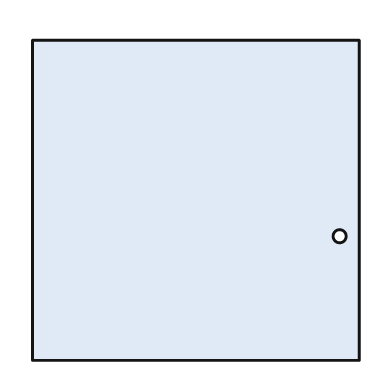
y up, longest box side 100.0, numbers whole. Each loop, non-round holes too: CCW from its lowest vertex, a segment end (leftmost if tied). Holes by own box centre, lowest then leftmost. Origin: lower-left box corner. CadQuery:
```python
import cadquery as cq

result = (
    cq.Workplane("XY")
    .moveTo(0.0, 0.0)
    .lineTo(100.0, 0.0)
    .lineTo(100.0, 98.0)
    .lineTo(0.0, 98.0)
    .close()
    .moveTo(94.0, 38.0)
    .circle(2.0)
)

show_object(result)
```